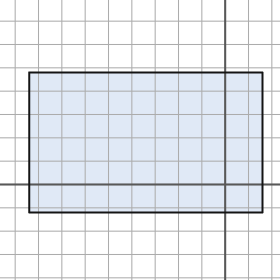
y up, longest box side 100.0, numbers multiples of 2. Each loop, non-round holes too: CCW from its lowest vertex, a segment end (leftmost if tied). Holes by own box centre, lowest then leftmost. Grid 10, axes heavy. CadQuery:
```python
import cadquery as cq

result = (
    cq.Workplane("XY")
    .moveTo(-84.0, -12.0)
    .lineTo(16.0, -12.0)
    .lineTo(16.0, 48.0)
    .lineTo(-84.0, 48.0)
    .close()
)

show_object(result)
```